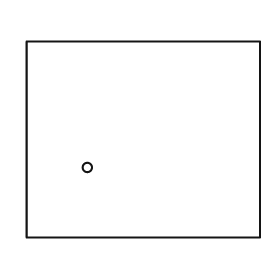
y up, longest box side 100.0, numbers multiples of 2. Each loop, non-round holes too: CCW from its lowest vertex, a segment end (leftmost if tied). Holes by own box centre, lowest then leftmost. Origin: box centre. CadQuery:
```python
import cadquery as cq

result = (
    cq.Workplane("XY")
    .moveTo(-50.0, -42.0)
    .lineTo(50.0, -42.0)
    .lineTo(50.0, 42.0)
    .lineTo(-50.0, 42.0)
    .close()
    .moveTo(-24.0, -12.0)
    .circle(2.0)
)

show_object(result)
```